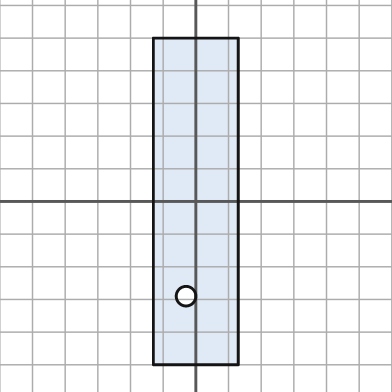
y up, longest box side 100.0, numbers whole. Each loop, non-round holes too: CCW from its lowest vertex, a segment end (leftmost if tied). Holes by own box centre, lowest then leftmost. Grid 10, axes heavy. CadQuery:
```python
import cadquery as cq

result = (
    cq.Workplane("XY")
    .moveTo(-13.0, -50.0)
    .lineTo(13.0, -50.0)
    .lineTo(13.0, 50.0)
    .lineTo(-13.0, 50.0)
    .close()
    .moveTo(-3.0, -29.0)
    .circle(3.0)
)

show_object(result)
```